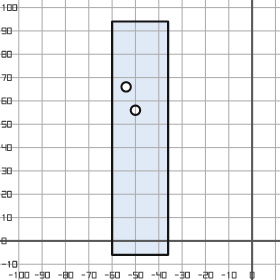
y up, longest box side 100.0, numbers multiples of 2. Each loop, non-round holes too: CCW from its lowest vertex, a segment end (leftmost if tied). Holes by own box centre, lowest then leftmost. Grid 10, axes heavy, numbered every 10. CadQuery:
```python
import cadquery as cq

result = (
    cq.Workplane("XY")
    .moveTo(-60.0, -6.0)
    .lineTo(-36.0, -6.0)
    .lineTo(-36.0, 94.0)
    .lineTo(-60.0, 94.0)
    .close()
    .moveTo(-50.0, 56.0)
    .circle(2.0)
    .moveTo(-54.0, 66.0)
    .circle(2.0)
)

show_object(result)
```